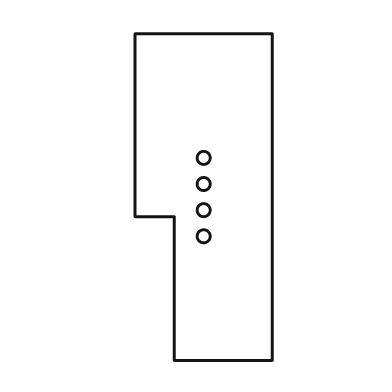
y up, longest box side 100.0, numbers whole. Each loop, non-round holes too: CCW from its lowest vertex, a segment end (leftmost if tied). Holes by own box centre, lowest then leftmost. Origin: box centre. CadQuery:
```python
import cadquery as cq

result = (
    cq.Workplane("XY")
    .moveTo(-9.0, -50.0)
    .lineTo(21.0, -50.0)
    .lineTo(21.0, 50.0)
    .lineTo(-21.0, 50.0)
    .lineTo(-21.0, -6.0)
    .lineTo(-9.0, -6.0)
    .close()
    .moveTo(0.0, -12.0)
    .circle(2.0)
    .moveTo(0.0, -4.0)
    .circle(2.0)
    .moveTo(0.0, 4.0)
    .circle(2.0)
    .moveTo(0.0, 12.0)
    .circle(2.0)
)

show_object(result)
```